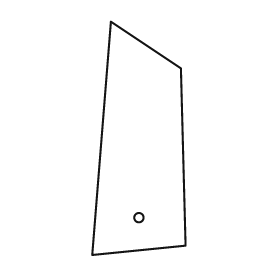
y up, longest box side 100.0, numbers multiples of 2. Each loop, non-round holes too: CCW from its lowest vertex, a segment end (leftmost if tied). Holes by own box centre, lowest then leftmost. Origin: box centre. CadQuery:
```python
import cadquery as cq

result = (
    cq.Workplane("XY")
    .moveTo(-20.0, -50.0)
    .lineTo(20.0, -46.0)
    .lineTo(18.0, 30.0)
    .lineTo(-12.0, 50.0)
    .close()
    .moveTo(0.0, -34.0)
    .circle(2.0)
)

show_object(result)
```